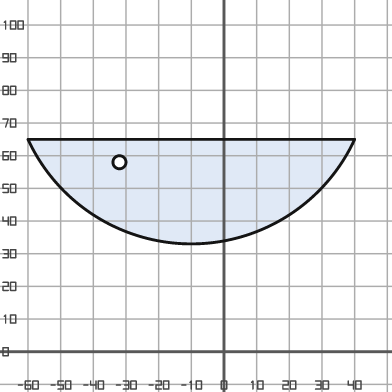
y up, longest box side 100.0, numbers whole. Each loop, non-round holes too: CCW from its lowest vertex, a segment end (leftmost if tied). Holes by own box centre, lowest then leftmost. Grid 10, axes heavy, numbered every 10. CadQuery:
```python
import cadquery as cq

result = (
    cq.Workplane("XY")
    .moveTo(-60.0, 65.0)
    .threePointArc((-10.0, 33.0), (40.0, 65.0))
    .close()
    .moveTo(-32.0, 58.0)
    .circle(2.0)
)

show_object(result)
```